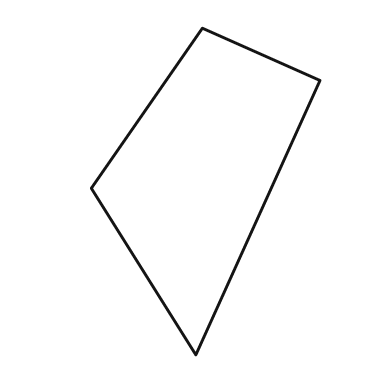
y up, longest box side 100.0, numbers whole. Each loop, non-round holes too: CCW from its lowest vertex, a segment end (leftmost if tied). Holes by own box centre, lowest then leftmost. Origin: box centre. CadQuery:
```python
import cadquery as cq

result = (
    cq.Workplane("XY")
    .moveTo(-3.0, -50.0)
    .lineTo(35.0, 34.0)
    .lineTo(-1.0, 50.0)
    .lineTo(-35.0, 1.0)
    .close()
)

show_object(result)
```